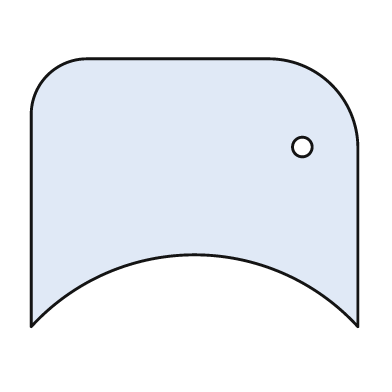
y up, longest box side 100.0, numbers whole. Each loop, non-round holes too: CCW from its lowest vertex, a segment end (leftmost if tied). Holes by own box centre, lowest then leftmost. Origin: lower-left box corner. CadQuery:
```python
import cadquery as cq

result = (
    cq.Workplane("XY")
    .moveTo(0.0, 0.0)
    .threePointArc((50.0, 22.0), (100.0, 0.0))
    .lineTo(100.0, 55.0)
    .threePointArc((92.0, 74.0), (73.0, 82.0))
    .lineTo(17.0, 82.0)
    .threePointArc((5.0, 77.0), (0.0, 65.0))
    .close()
    .moveTo(83.0, 55.0)
    .circle(3.0)
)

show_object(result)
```